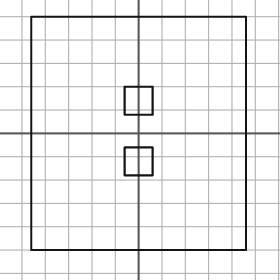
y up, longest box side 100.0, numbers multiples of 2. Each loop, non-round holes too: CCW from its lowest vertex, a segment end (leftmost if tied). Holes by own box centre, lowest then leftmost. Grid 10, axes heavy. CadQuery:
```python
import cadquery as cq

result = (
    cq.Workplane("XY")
    .moveTo(-46.0, -50.0)
    .lineTo(46.0, -50.0)
    .lineTo(46.0, 50.0)
    .lineTo(-46.0, 50.0)
    .close()
    .moveTo(-6.0, -18.0)
    .lineTo(6.0, -18.0)
    .lineTo(6.0, -6.0)
    .lineTo(-6.0, -6.0)
    .close()
    .moveTo(-6.0, 8.0)
    .lineTo(6.0, 8.0)
    .lineTo(6.0, 20.0)
    .lineTo(-6.0, 20.0)
    .close()
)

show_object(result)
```